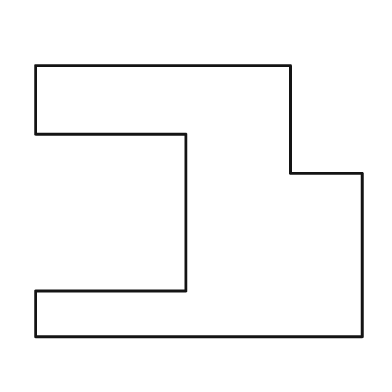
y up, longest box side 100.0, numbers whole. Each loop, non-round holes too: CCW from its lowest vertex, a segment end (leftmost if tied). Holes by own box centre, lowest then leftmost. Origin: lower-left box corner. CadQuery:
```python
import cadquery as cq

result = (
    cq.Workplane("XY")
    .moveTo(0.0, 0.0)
    .lineTo(100.0, 0.0)
    .lineTo(100.0, 50.0)
    .lineTo(78.0, 50.0)
    .lineTo(78.0, 83.0)
    .lineTo(0.0, 83.0)
    .lineTo(0.0, 62.0)
    .lineTo(46.0, 62.0)
    .lineTo(46.0, 14.0)
    .lineTo(0.0, 14.0)
    .close()
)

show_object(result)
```